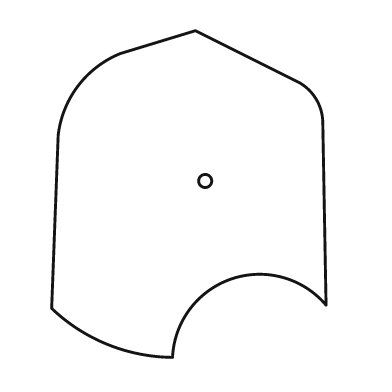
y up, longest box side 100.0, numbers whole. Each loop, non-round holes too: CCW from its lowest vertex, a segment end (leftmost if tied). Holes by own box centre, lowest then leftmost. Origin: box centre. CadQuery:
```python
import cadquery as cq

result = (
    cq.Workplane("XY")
    .moveTo(-5.0, -50.0)
    .threePointArc((13.0, -26.0), (42.0, -34.0))
    .lineTo(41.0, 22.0)
    .threePointArc((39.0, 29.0), (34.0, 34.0))
    .lineTo(2.0, 50.0)
    .lineTo(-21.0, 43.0)
    .threePointArc((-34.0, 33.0), (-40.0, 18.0))
    .lineTo(-42.0, -35.0)
    .threePointArc((-25.0, -46.0), (-5.0, -50.0))
    .close()
    .moveTo(5.0, 4.0)
    .circle(2.0)
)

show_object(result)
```